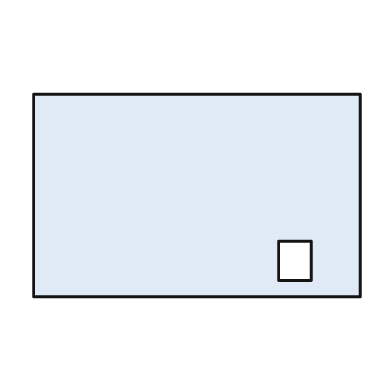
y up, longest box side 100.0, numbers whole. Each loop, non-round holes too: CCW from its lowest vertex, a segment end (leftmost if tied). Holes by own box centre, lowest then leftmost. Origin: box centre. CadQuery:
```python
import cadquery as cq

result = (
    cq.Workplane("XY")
    .moveTo(-50.0, -31.0)
    .lineTo(50.0, -31.0)
    .lineTo(50.0, 31.0)
    .lineTo(-50.0, 31.0)
    .close()
    .moveTo(25.0, -26.0)
    .lineTo(35.0, -26.0)
    .lineTo(35.0, -14.0)
    .lineTo(25.0, -14.0)
    .close()
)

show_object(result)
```